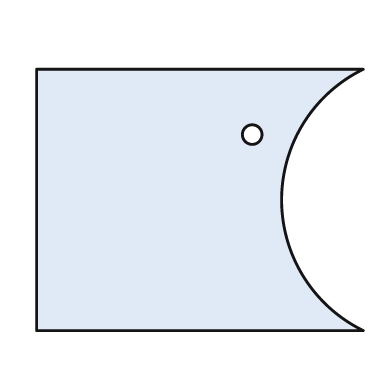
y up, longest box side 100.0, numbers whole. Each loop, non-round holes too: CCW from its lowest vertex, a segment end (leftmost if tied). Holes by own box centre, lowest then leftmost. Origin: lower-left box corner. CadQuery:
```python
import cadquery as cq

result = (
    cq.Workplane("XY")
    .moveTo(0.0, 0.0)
    .lineTo(100.0, 0.0)
    .threePointArc((75.0, 40.0), (100.0, 80.0))
    .lineTo(0.0, 80.0)
    .close()
    .moveTo(66.0, 60.0)
    .circle(3.0)
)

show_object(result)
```